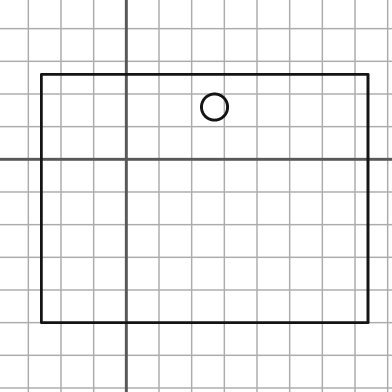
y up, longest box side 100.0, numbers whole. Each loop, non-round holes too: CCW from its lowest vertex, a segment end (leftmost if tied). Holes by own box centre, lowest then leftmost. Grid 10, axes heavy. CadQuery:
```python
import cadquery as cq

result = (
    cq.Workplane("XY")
    .moveTo(-26.0, -50.0)
    .lineTo(74.0, -50.0)
    .lineTo(74.0, 26.0)
    .lineTo(-26.0, 26.0)
    .close()
    .moveTo(27.0, 16.0)
    .circle(4.0)
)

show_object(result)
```